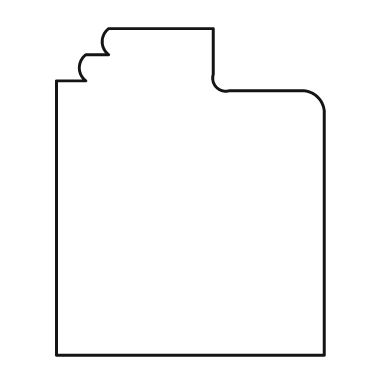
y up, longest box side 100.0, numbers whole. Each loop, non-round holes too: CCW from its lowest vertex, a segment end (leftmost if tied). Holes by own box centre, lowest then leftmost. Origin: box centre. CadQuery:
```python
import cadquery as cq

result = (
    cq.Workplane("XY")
    .moveTo(-41.0, -50.0)
    .lineTo(41.0, -50.0)
    .lineTo(41.0, 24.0)
    .threePointArc((39.0, 29.0), (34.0, 31.0))
    .lineTo(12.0, 31.0)
    .threePointArc((8.0, 32.0), (7.0, 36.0))
    .lineTo(7.0, 50.0)
    .lineTo(-25.0, 50.0)
    .threePointArc((-27.0, 46.0), (-25.0, 42.0))
    .lineTo(-32.0, 42.0)
    .threePointArc((-34.0, 38.0), (-32.0, 34.0))
    .lineTo(-41.0, 34.0)
    .close()
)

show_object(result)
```